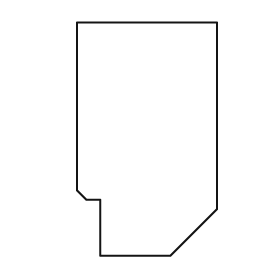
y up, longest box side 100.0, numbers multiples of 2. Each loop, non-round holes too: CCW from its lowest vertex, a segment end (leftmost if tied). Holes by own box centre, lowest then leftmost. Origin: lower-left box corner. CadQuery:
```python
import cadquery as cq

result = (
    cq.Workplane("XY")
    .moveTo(10.0, 0.0)
    .lineTo(40.0, 0.0)
    .lineTo(60.0, 20.0)
    .lineTo(60.0, 100.0)
    .lineTo(0.0, 100.0)
    .lineTo(0.0, 28.0)
    .lineTo(4.0, 24.0)
    .lineTo(10.0, 24.0)
    .close()
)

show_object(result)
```